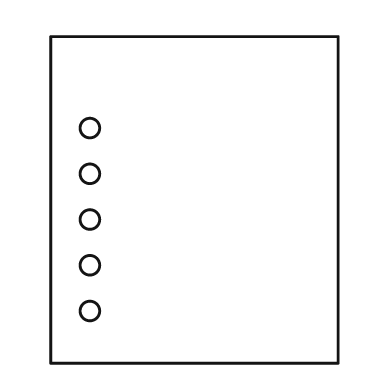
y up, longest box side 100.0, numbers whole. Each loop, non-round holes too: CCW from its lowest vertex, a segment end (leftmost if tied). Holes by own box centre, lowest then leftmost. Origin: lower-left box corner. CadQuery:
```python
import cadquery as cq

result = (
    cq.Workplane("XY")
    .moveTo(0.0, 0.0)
    .lineTo(88.0, 0.0)
    .lineTo(88.0, 100.0)
    .lineTo(0.0, 100.0)
    .close()
    .moveTo(12.0, 16.0)
    .circle(3.0)
    .moveTo(12.0, 30.0)
    .circle(3.0)
    .moveTo(12.0, 44.0)
    .circle(3.0)
    .moveTo(12.0, 58.0)
    .circle(3.0)
    .moveTo(12.0, 72.0)
    .circle(3.0)
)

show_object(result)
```